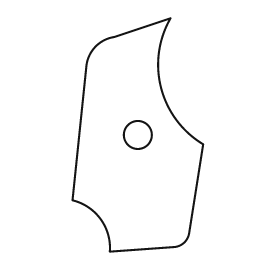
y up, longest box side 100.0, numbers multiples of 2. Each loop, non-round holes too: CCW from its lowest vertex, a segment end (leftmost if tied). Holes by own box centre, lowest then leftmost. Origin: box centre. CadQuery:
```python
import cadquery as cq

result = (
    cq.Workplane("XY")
    .moveTo(-12.0, -50.0)
    .lineTo(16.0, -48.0)
    .threePointArc((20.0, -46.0), (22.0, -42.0))
    .lineTo(28.0, -4.0)
    .threePointArc((10.0, 20.0), (14.0, 50.0))
    .lineTo(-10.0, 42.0)
    .threePointArc((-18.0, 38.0), (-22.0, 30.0))
    .lineTo(-28.0, -28.0)
    .threePointArc((-16.0, -36.0), (-12.0, -50.0))
    .close()
    .moveTo(0.0, 0.0)
    .circle(6.0)
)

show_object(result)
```